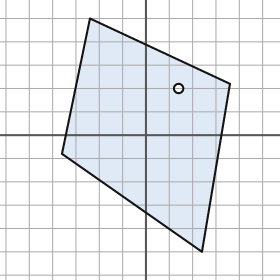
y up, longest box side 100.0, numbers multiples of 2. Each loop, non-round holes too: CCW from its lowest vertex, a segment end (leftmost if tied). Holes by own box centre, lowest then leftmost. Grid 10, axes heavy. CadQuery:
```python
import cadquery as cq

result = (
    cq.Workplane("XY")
    .moveTo(24.0, -50.0)
    .lineTo(36.0, 22.0)
    .lineTo(-24.0, 50.0)
    .lineTo(-36.0, -8.0)
    .close()
    .moveTo(14.0, 20.0)
    .circle(2.0)
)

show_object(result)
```